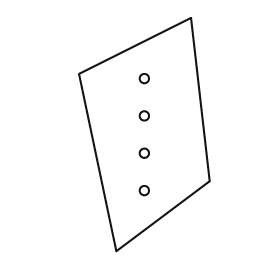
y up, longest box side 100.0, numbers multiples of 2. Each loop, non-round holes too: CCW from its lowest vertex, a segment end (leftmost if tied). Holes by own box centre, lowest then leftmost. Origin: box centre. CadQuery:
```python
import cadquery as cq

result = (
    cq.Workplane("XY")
    .moveTo(-12.0, -50.0)
    .lineTo(28.0, -20.0)
    .lineTo(20.0, 50.0)
    .lineTo(-28.0, 26.0)
    .close()
    .moveTo(0.0, -24.0)
    .circle(2.0)
    .moveTo(0.0, -8.0)
    .circle(2.0)
    .moveTo(0.0, 8.0)
    .circle(2.0)
    .moveTo(0.0, 24.0)
    .circle(2.0)
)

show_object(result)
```